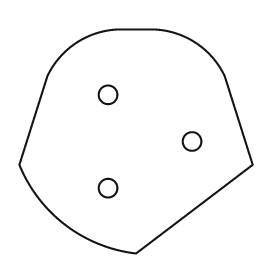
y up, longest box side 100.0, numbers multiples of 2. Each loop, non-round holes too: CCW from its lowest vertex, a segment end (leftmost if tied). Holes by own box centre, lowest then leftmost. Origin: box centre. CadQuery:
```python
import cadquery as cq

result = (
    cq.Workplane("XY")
    .moveTo(0.0, -48.0)
    .lineTo(50.0, -10.0)
    .lineTo(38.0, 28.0)
    .threePointArc((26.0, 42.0), (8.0, 48.0))
    .lineTo(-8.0, 48.0)
    .threePointArc((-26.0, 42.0), (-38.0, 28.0))
    .lineTo(-50.0, -10.0)
    .threePointArc((-30.0, -36.0), (0.0, -48.0))
    .close()
    .moveTo(-12.0, -20.0)
    .circle(4.0)
    .moveTo(24.0, 0.0)
    .circle(4.0)
    .moveTo(-12.0, 20.0)
    .circle(4.0)
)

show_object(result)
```